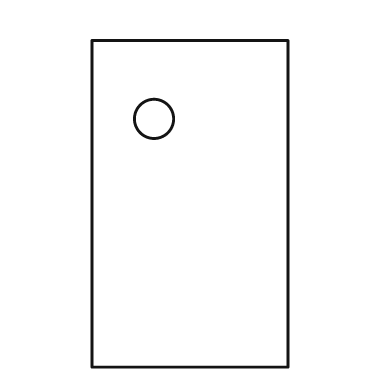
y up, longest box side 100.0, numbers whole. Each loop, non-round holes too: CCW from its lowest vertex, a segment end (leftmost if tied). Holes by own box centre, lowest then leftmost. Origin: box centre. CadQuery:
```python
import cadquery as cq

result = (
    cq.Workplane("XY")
    .moveTo(-30.0, -50.0)
    .lineTo(30.0, -50.0)
    .lineTo(30.0, 50.0)
    .lineTo(-30.0, 50.0)
    .close()
    .moveTo(-11.0, 26.0)
    .circle(6.0)
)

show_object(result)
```